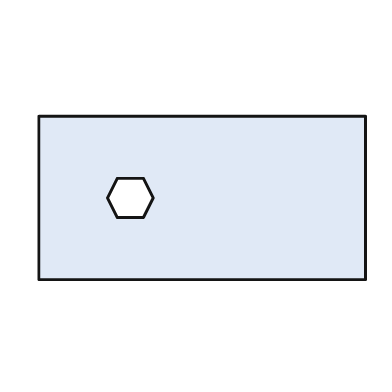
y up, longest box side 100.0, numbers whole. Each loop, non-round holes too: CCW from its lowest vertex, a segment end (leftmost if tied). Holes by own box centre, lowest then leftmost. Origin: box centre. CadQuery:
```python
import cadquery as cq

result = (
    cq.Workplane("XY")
    .moveTo(-50.0, -25.0)
    .lineTo(50.0, -25.0)
    .lineTo(50.0, 25.0)
    .lineTo(-50.0, 25.0)
    .close()
    .moveTo(-26.0, -6.0)
    .lineTo(-18.0, -6.0)
    .lineTo(-15.0, 0.0)
    .lineTo(-18.0, 6.0)
    .lineTo(-26.0, 6.0)
    .lineTo(-29.0, 0.0)
    .close()
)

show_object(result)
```